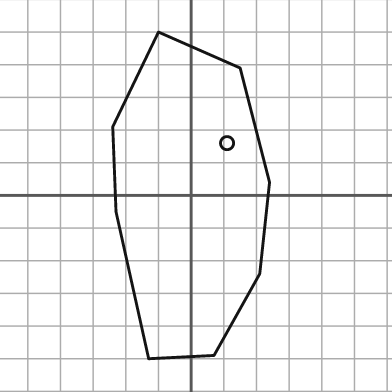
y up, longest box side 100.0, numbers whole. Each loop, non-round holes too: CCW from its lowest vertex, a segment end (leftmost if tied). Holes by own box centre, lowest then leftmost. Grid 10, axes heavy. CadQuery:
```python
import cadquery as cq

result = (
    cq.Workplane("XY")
    .moveTo(-13.0, -50.0)
    .lineTo(7.0, -49.0)
    .lineTo(21.0, -24.0)
    .lineTo(24.0, 4.0)
    .lineTo(15.0, 39.0)
    .lineTo(-10.0, 50.0)
    .lineTo(-24.0, 21.0)
    .lineTo(-23.0, -5.0)
    .close()
    .moveTo(11.0, 16.0)
    .circle(2.0)
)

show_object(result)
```